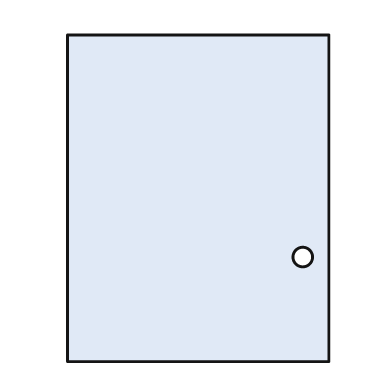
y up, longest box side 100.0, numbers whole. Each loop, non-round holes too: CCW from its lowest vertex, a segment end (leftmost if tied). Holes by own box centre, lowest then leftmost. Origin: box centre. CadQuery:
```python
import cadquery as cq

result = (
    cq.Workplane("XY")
    .moveTo(-40.0, -50.0)
    .lineTo(40.0, -50.0)
    .lineTo(40.0, 50.0)
    .lineTo(-40.0, 50.0)
    .close()
    .moveTo(32.0, -18.0)
    .circle(3.0)
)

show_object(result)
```